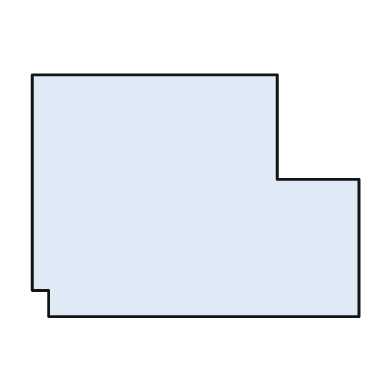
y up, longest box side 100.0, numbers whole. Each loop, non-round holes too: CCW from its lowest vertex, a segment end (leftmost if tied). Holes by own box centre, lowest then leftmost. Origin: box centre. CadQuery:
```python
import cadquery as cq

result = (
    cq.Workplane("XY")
    .moveTo(-45.0, -37.0)
    .lineTo(50.0, -37.0)
    .lineTo(50.0, 5.0)
    .lineTo(25.0, 5.0)
    .lineTo(25.0, 37.0)
    .lineTo(-50.0, 37.0)
    .lineTo(-50.0, -29.0)
    .lineTo(-45.0, -29.0)
    .close()
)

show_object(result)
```